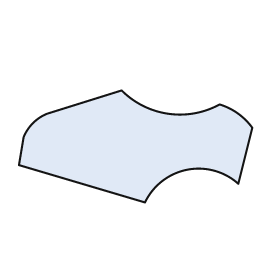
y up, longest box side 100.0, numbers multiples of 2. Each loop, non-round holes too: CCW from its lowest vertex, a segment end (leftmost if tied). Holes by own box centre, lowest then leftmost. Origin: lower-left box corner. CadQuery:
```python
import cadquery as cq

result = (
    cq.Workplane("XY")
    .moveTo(54.0, 0.0)
    .threePointArc((72.0, 14.0), (94.0, 8.0))
    .lineTo(100.0, 32.0)
    .threePointArc((94.0, 38.0), (86.0, 42.0))
    .threePointArc((64.0, 38.0), (44.0, 48.0))
    .lineTo(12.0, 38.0)
    .threePointArc((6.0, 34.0), (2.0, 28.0))
    .lineTo(0.0, 16.0)
    .close()
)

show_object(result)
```